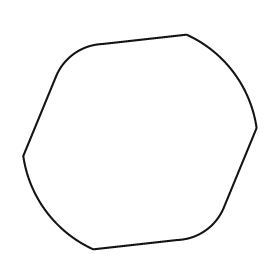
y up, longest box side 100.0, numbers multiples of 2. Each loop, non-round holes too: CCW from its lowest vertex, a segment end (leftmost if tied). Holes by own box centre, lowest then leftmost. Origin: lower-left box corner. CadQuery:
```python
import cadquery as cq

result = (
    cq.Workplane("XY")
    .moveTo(30.0, 0.0)
    .lineTo(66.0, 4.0)
    .threePointArc((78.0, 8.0), (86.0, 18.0))
    .lineTo(100.0, 52.0)
    .threePointArc((90.0, 76.0), (70.0, 92.0))
    .lineTo(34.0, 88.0)
    .threePointArc((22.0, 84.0), (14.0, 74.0))
    .lineTo(0.0, 40.0)
    .threePointArc((10.0, 16.0), (30.0, 0.0))
    .close()
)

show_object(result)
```